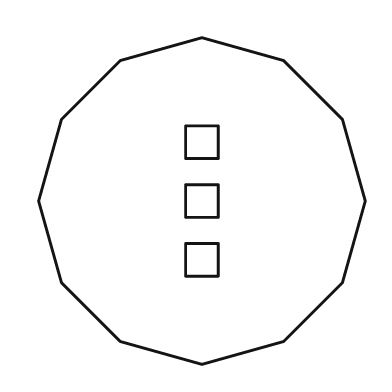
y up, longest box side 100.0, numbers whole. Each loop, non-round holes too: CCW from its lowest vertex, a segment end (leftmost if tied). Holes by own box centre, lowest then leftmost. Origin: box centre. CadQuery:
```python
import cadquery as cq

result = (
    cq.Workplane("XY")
    .moveTo(0.0, -50.0)
    .lineTo(25.0, -43.0)
    .lineTo(43.0, -25.0)
    .lineTo(50.0, 0.0)
    .lineTo(43.0, 25.0)
    .lineTo(25.0, 43.0)
    .lineTo(0.0, 50.0)
    .lineTo(-25.0, 43.0)
    .lineTo(-43.0, 25.0)
    .lineTo(-50.0, 0.0)
    .lineTo(-43.0, -25.0)
    .lineTo(-25.0, -43.0)
    .close()
    .moveTo(-5.0, -23.0)
    .lineTo(5.0, -23.0)
    .lineTo(5.0, -13.0)
    .lineTo(-5.0, -13.0)
    .close()
    .moveTo(-5.0, -5.0)
    .lineTo(5.0, -5.0)
    .lineTo(5.0, 5.0)
    .lineTo(-5.0, 5.0)
    .close()
    .moveTo(-5.0, 13.0)
    .lineTo(5.0, 13.0)
    .lineTo(5.0, 23.0)
    .lineTo(-5.0, 23.0)
    .close()
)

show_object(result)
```